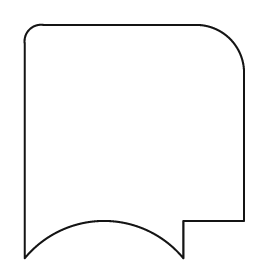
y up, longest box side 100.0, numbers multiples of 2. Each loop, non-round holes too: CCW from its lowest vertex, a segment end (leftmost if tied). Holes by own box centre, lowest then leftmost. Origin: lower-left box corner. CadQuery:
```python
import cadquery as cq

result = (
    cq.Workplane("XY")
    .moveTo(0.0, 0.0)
    .threePointArc((34.0, 16.0), (68.0, 0.0))
    .lineTo(68.0, 16.0)
    .lineTo(94.0, 16.0)
    .lineTo(94.0, 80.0)
    .threePointArc((88.0, 94.0), (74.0, 100.0))
    .lineTo(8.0, 100.0)
    .threePointArc((2.0, 98.0), (0.0, 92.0))
    .close()
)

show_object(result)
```